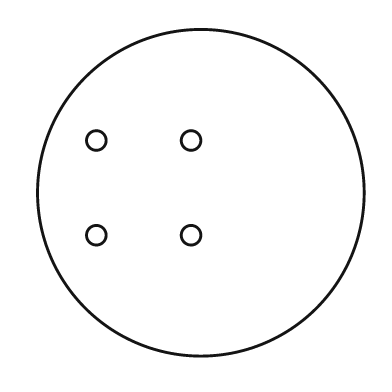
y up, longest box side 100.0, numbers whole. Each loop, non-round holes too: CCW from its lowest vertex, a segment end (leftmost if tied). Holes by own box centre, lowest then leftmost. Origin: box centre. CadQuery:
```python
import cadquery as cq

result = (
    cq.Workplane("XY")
    .moveTo(0.0, 0.0)
    .circle(50.0)
    .moveTo(-32.0, -13.0)
    .circle(3.0)
    .moveTo(-3.0, -13.0)
    .circle(3.0)
    .moveTo(-32.0, 16.0)
    .circle(3.0)
    .moveTo(-3.0, 16.0)
    .circle(3.0)
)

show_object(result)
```